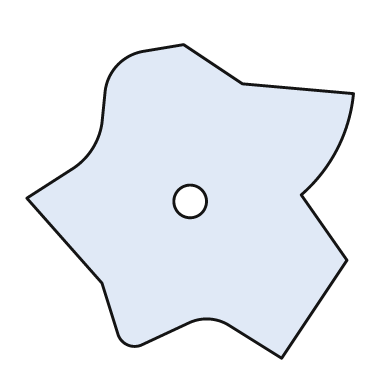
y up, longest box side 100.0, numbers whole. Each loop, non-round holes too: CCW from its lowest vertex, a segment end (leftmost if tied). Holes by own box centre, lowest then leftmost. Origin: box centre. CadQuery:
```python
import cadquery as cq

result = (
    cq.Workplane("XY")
    .moveTo(28.0, -48.0)
    .lineTo(48.0, -18.0)
    .lineTo(34.0, 2.0)
    .threePointArc((45.0, 16.0), (50.0, 33.0))
    .lineTo(16.0, 36.0)
    .lineTo(-2.0, 48.0)
    .lineTo(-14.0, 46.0)
    .threePointArc((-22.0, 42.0), (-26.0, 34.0))
    .lineTo(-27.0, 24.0)
    .threePointArc((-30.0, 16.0), (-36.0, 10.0))
    .lineTo(-50.0, 1.0)
    .lineTo(-27.0, -25.0)
    .lineTo(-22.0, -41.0)
    .threePointArc((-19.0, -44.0), (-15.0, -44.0))
    .lineTo(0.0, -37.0)
    .threePointArc((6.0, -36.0), (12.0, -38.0))
    .close()
    .moveTo(0.0, 0.0)
    .circle(5.0)
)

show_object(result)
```